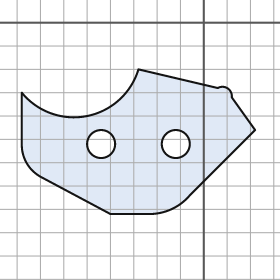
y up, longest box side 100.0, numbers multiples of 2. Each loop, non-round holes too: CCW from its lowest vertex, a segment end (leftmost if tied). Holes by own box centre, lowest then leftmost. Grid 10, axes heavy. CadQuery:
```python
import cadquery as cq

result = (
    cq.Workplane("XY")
    .moveTo(-40.0, -82.0)
    .lineTo(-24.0, -82.0)
    .threePointArc((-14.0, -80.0), (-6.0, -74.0))
    .lineTo(22.0, -46.0)
    .lineTo(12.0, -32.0)
    .threePointArc((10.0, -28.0), (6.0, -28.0))
    .lineTo(-28.0, -20.0)
    .threePointArc((-50.0, -40.0), (-78.0, -30.0))
    .lineTo(-78.0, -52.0)
    .threePointArc((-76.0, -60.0), (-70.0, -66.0))
    .close()
    .moveTo(-44.0, -52.0)
    .circle(6.0)
    .moveTo(-12.0, -52.0)
    .circle(6.0)
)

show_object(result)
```